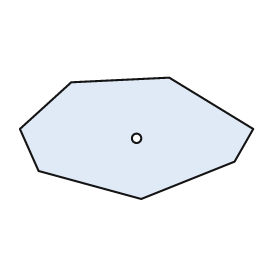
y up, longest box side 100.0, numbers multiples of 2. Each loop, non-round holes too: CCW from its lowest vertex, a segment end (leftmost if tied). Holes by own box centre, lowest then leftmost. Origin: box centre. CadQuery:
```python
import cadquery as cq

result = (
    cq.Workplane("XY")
    .moveTo(2.0, -26.0)
    .lineTo(42.0, -10.0)
    .lineTo(50.0, 4.0)
    .lineTo(14.0, 26.0)
    .lineTo(-28.0, 24.0)
    .lineTo(-50.0, 4.0)
    .lineTo(-42.0, -14.0)
    .close()
    .moveTo(0.0, 0.0)
    .circle(2.0)
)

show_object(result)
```